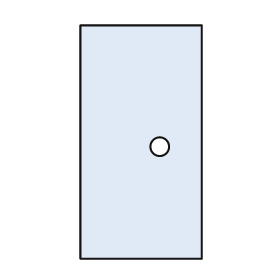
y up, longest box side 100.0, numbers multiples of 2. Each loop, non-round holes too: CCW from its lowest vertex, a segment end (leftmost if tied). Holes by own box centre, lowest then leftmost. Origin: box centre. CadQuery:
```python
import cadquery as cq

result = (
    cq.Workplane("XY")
    .moveTo(-26.0, -50.0)
    .lineTo(26.0, -50.0)
    .lineTo(26.0, 50.0)
    .lineTo(-26.0, 50.0)
    .close()
    .moveTo(8.0, -2.0)
    .circle(4.0)
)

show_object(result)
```